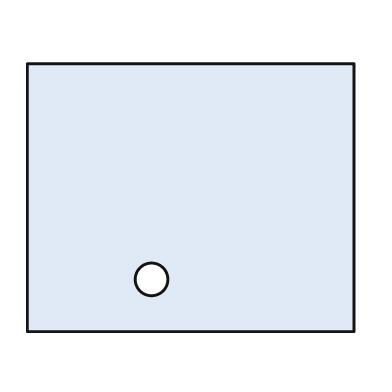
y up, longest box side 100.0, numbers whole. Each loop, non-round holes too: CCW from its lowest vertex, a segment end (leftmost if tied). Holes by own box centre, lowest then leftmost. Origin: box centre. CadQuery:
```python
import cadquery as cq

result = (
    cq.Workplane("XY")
    .moveTo(-50.0, -41.0)
    .lineTo(50.0, -41.0)
    .lineTo(50.0, 41.0)
    .lineTo(-50.0, 41.0)
    .close()
    .moveTo(-12.0, -25.0)
    .circle(5.0)
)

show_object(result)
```